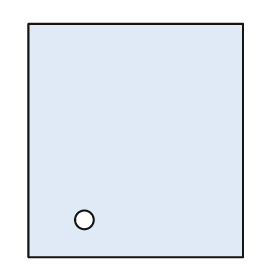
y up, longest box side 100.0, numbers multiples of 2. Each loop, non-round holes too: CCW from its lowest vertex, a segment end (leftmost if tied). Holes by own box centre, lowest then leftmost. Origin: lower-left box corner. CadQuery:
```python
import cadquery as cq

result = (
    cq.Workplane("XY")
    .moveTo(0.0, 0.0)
    .lineTo(92.0, 0.0)
    .lineTo(92.0, 100.0)
    .lineTo(0.0, 100.0)
    .close()
    .moveTo(24.0, 16.0)
    .circle(4.0)
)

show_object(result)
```